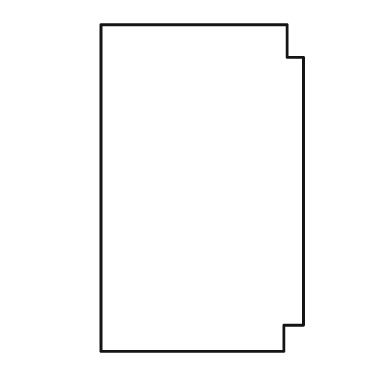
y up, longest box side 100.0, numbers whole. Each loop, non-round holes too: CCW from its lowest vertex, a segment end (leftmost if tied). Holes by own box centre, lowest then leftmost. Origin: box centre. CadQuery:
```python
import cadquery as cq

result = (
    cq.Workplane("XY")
    .moveTo(-31.0, -50.0)
    .lineTo(25.0, -50.0)
    .lineTo(25.0, -42.0)
    .lineTo(31.0, -42.0)
    .lineTo(31.0, 40.0)
    .lineTo(26.0, 40.0)
    .lineTo(26.0, 50.0)
    .lineTo(-31.0, 50.0)
    .close()
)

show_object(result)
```